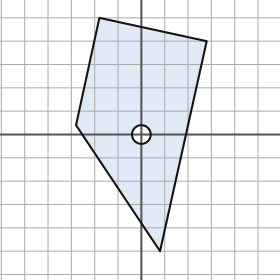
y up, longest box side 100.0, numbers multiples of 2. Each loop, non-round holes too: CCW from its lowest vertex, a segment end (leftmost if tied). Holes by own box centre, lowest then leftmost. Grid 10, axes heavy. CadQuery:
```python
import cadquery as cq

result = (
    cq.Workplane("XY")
    .moveTo(8.0, -50.0)
    .lineTo(28.0, 40.0)
    .lineTo(-18.0, 50.0)
    .lineTo(-28.0, 4.0)
    .close()
    .moveTo(0.0, 0.0)
    .circle(4.0)
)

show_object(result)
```